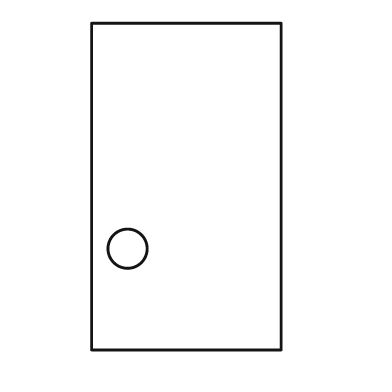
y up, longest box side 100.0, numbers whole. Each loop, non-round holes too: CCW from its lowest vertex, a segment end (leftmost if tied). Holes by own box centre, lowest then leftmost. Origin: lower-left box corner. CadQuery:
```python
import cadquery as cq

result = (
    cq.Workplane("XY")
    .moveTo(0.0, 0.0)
    .lineTo(58.0, 0.0)
    .lineTo(58.0, 100.0)
    .lineTo(0.0, 100.0)
    .close()
    .moveTo(11.0, 31.0)
    .circle(6.0)
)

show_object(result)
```